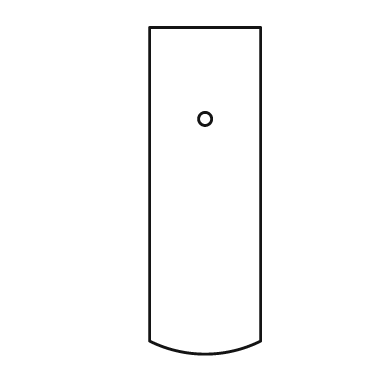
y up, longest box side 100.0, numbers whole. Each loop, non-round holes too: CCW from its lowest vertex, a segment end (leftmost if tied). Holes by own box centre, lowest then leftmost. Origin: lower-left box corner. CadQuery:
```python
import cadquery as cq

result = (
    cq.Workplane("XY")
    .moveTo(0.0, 4.0)
    .threePointArc((17.0, 0.0), (34.0, 4.0))
    .lineTo(34.0, 100.0)
    .lineTo(0.0, 100.0)
    .close()
    .moveTo(17.0, 72.0)
    .circle(2.0)
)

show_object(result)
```